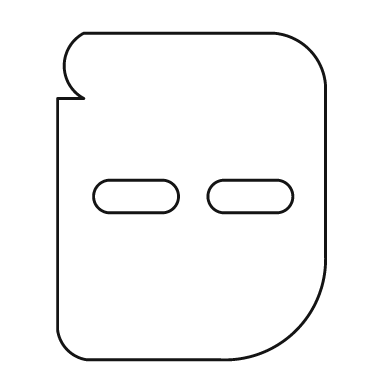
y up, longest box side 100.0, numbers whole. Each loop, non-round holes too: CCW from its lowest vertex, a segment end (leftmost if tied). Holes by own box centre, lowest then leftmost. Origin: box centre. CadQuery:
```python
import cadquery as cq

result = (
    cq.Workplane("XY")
    .moveTo(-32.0, -50.0)
    .lineTo(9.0, -50.0)
    .threePointArc((32.0, -41.0), (41.0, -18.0))
    .lineTo(41.0, 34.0)
    .threePointArc((36.0, 45.0), (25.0, 50.0))
    .lineTo(-33.0, 50.0)
    .threePointArc((-39.0, 40.0), (-33.0, 30.0))
    .lineTo(-41.0, 30.0)
    .lineTo(-41.0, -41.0)
    .threePointArc((-38.0, -47.0), (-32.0, -50.0))
    .close()
    .moveTo(-25.0, -5.0)
    .lineTo(-9.0, -5.0)
    .threePointArc((-4.0, 0.0), (-9.0, 5.0))
    .lineTo(-25.0, 5.0)
    .threePointArc((-30.0, 0.0), (-25.0, -5.0))
    .close()
    .moveTo(10.0, -5.0)
    .lineTo(26.0, -5.0)
    .threePointArc((31.0, 0.0), (26.0, 5.0))
    .lineTo(10.0, 5.0)
    .threePointArc((5.0, 0.0), (10.0, -5.0))
    .close()
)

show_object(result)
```